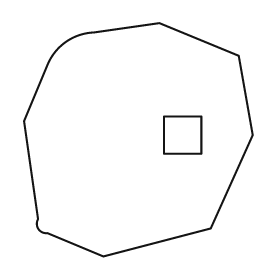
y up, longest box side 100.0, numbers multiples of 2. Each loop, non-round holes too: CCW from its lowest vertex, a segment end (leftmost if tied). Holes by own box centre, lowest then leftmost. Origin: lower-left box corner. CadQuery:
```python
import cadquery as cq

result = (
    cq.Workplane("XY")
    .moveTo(34.0, 0.0)
    .lineTo(80.0, 12.0)
    .lineTo(98.0, 52.0)
    .lineTo(92.0, 86.0)
    .lineTo(58.0, 100.0)
    .lineTo(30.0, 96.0)
    .threePointArc((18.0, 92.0), (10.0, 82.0))
    .lineTo(0.0, 58.0)
    .lineTo(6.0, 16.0)
    .threePointArc((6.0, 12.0), (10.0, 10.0))
    .close()
    .moveTo(60.0, 44.0)
    .lineTo(76.0, 44.0)
    .lineTo(76.0, 60.0)
    .lineTo(60.0, 60.0)
    .close()
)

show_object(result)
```